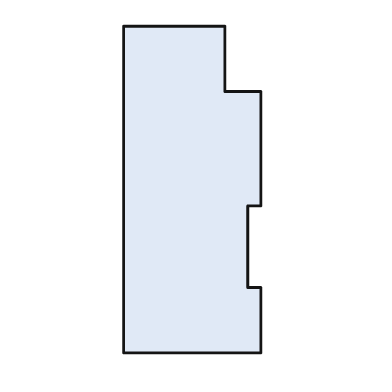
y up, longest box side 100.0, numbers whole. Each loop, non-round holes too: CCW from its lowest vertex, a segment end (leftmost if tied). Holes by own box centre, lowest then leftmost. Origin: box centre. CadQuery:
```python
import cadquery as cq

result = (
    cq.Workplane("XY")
    .moveTo(-21.0, -50.0)
    .lineTo(21.0, -50.0)
    .lineTo(21.0, -30.0)
    .lineTo(17.0, -30.0)
    .lineTo(17.0, -5.0)
    .lineTo(21.0, -5.0)
    .lineTo(21.0, 30.0)
    .lineTo(10.0, 30.0)
    .lineTo(10.0, 50.0)
    .lineTo(-21.0, 50.0)
    .close()
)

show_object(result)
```